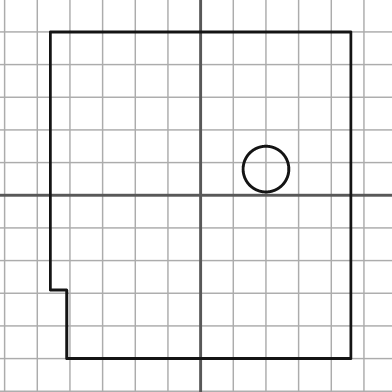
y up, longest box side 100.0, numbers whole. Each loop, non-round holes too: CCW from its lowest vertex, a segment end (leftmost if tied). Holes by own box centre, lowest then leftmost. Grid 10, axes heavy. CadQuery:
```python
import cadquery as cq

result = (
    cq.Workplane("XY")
    .moveTo(-41.0, -50.0)
    .lineTo(46.0, -50.0)
    .lineTo(46.0, 50.0)
    .lineTo(-46.0, 50.0)
    .lineTo(-46.0, -29.0)
    .lineTo(-41.0, -29.0)
    .close()
    .moveTo(20.0, 8.0)
    .circle(7.0)
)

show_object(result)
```